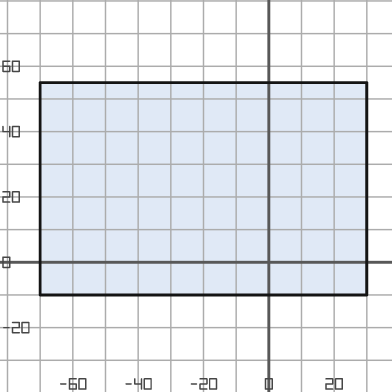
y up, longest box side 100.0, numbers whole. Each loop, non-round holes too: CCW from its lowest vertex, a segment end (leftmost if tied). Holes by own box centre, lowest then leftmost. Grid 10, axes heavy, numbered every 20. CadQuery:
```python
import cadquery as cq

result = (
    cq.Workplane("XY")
    .moveTo(-70.0, -10.0)
    .lineTo(30.0, -10.0)
    .lineTo(30.0, 55.0)
    .lineTo(-70.0, 55.0)
    .close()
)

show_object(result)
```